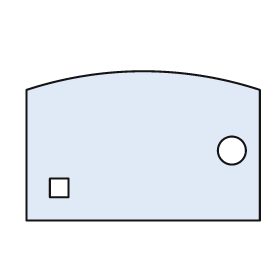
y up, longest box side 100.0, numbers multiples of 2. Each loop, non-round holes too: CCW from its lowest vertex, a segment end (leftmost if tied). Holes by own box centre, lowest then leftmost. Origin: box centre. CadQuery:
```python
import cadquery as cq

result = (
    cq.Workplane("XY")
    .moveTo(-50.0, -32.0)
    .lineTo(50.0, -32.0)
    .lineTo(50.0, 24.0)
    .threePointArc((0.0, 32.0), (-50.0, 24.0))
    .close()
    .moveTo(-40.0, -22.0)
    .lineTo(-32.0, -22.0)
    .lineTo(-32.0, -14.0)
    .lineTo(-40.0, -14.0)
    .close()
    .moveTo(38.0, -2.0)
    .circle(6.0)
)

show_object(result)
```